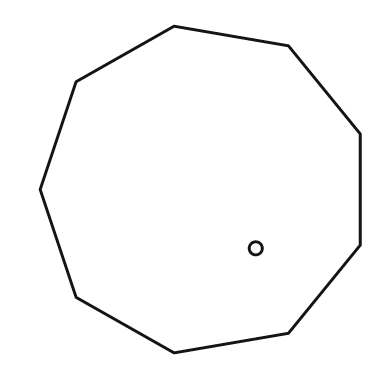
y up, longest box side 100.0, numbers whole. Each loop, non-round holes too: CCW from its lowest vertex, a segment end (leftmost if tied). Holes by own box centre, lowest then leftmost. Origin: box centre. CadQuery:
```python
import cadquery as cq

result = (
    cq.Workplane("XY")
    .moveTo(-8.0, -50.0)
    .lineTo(27.0, -44.0)
    .lineTo(49.0, -17.0)
    .lineTo(49.0, 17.0)
    .lineTo(27.0, 44.0)
    .lineTo(-8.0, 50.0)
    .lineTo(-38.0, 33.0)
    .lineTo(-49.0, 0.0)
    .lineTo(-38.0, -33.0)
    .close()
    .moveTo(17.0, -18.0)
    .circle(2.0)
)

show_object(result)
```